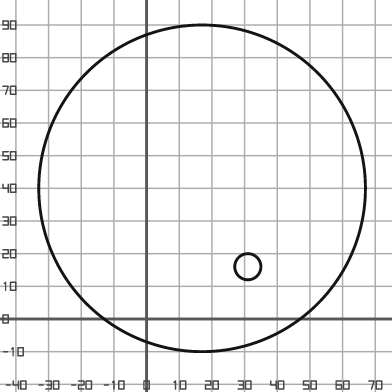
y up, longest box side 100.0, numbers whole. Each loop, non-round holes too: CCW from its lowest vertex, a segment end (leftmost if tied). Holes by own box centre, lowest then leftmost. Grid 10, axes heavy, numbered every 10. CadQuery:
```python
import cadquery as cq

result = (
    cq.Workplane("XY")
    .moveTo(17.0, 40.0)
    .circle(50.0)
    .moveTo(31.0, 16.0)
    .circle(4.0)
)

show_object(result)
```